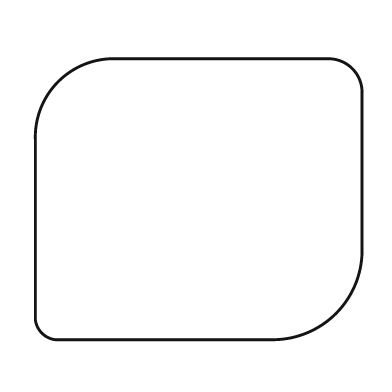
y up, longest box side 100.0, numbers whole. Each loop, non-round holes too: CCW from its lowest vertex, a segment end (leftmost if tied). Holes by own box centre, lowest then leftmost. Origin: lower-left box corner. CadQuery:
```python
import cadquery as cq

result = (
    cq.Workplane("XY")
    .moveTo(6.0, 0.0)
    .lineTo(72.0, 0.0)
    .threePointArc((92.0, 8.0), (100.0, 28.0))
    .lineTo(100.0, 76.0)
    .threePointArc((97.0, 83.0), (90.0, 86.0))
    .lineTo(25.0, 86.0)
    .threePointArc((7.0, 79.0), (0.0, 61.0))
    .lineTo(0.0, 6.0)
    .threePointArc((2.0, 2.0), (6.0, 0.0))
    .close()
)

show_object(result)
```